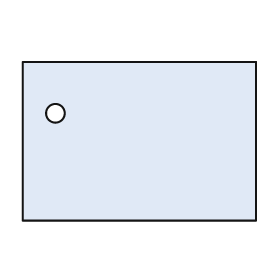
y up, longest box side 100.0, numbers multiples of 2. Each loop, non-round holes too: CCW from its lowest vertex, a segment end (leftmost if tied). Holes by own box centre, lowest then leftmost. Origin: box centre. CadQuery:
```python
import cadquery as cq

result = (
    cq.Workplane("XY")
    .moveTo(-50.0, -34.0)
    .lineTo(50.0, -34.0)
    .lineTo(50.0, 34.0)
    .lineTo(-50.0, 34.0)
    .close()
    .moveTo(-36.0, 12.0)
    .circle(4.0)
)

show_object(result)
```